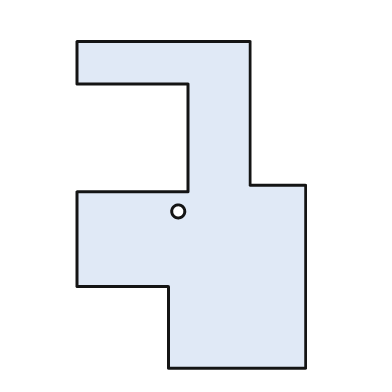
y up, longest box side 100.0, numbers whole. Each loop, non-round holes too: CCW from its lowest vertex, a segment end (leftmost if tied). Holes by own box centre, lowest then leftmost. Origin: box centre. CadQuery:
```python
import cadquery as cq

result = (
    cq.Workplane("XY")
    .moveTo(-7.0, -50.0)
    .lineTo(35.0, -50.0)
    .lineTo(35.0, 6.0)
    .lineTo(18.0, 6.0)
    .lineTo(18.0, 50.0)
    .lineTo(-35.0, 50.0)
    .lineTo(-35.0, 37.0)
    .lineTo(-1.0, 37.0)
    .lineTo(-1.0, 4.0)
    .lineTo(-35.0, 4.0)
    .lineTo(-35.0, -25.0)
    .lineTo(-7.0, -25.0)
    .close()
    .moveTo(-4.0, -2.0)
    .circle(2.0)
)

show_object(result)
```